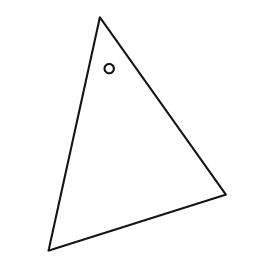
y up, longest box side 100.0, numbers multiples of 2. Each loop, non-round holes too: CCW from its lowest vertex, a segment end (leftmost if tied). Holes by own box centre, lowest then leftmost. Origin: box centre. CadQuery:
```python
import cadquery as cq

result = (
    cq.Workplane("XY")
    .moveTo(-38.0, -50.0)
    .lineTo(38.0, -26.0)
    .lineTo(-16.0, 50.0)
    .close()
    .moveTo(-12.0, 28.0)
    .circle(2.0)
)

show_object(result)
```